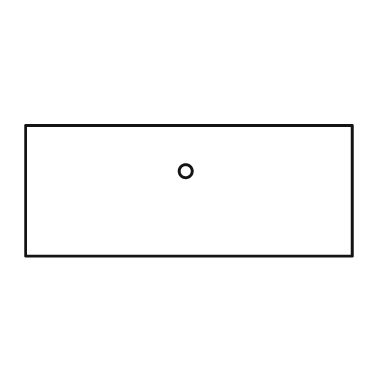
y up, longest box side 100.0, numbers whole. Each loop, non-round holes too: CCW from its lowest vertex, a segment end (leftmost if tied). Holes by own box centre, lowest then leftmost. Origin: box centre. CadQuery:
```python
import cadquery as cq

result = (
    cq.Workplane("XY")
    .moveTo(-50.0, -20.0)
    .lineTo(50.0, -20.0)
    .lineTo(50.0, 20.0)
    .lineTo(-50.0, 20.0)
    .close()
    .moveTo(-1.0, 6.0)
    .circle(2.0)
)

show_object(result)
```